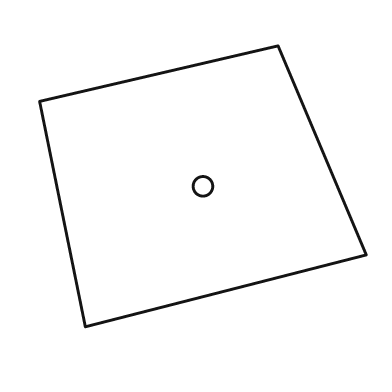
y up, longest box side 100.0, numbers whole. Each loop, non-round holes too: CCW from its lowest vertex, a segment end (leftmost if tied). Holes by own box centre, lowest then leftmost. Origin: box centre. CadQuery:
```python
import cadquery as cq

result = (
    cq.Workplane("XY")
    .moveTo(-36.0, -43.0)
    .lineTo(50.0, -21.0)
    .lineTo(23.0, 43.0)
    .lineTo(-50.0, 26.0)
    .close()
    .moveTo(0.0, 0.0)
    .circle(3.0)
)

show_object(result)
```